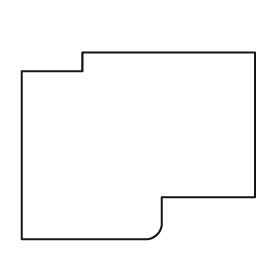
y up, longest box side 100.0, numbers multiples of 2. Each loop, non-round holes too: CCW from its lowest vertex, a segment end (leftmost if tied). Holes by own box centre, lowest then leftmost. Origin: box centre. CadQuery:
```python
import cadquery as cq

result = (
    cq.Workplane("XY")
    .moveTo(-50.0, -40.0)
    .lineTo(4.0, -40.0)
    .threePointArc((8.0, -38.0), (10.0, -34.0))
    .lineTo(10.0, -22.0)
    .lineTo(50.0, -22.0)
    .lineTo(50.0, 40.0)
    .lineTo(-24.0, 40.0)
    .lineTo(-24.0, 32.0)
    .lineTo(-50.0, 32.0)
    .close()
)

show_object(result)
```